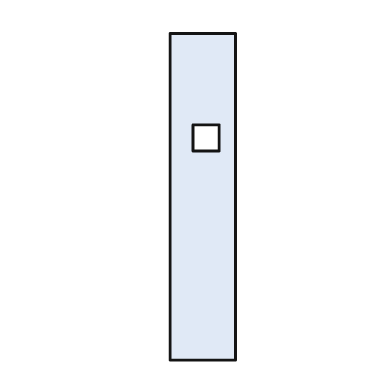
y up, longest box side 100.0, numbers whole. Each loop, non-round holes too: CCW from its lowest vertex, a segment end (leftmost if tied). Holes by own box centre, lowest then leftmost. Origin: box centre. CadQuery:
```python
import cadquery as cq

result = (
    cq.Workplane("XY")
    .moveTo(-10.0, -50.0)
    .lineTo(10.0, -50.0)
    .lineTo(10.0, 50.0)
    .lineTo(-10.0, 50.0)
    .close()
    .moveTo(-3.0, 14.0)
    .lineTo(5.0, 14.0)
    .lineTo(5.0, 22.0)
    .lineTo(-3.0, 22.0)
    .close()
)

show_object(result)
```